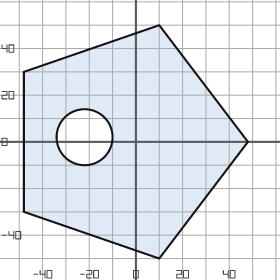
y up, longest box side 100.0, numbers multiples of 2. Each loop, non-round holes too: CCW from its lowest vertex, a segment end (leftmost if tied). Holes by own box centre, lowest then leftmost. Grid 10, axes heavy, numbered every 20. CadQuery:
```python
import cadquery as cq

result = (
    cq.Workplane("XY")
    .moveTo(10.0, -50.0)
    .lineTo(48.0, 0.0)
    .lineTo(10.0, 50.0)
    .lineTo(-48.0, 30.0)
    .lineTo(-48.0, -30.0)
    .close()
    .moveTo(-22.0, 2.0)
    .circle(12.0)
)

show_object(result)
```